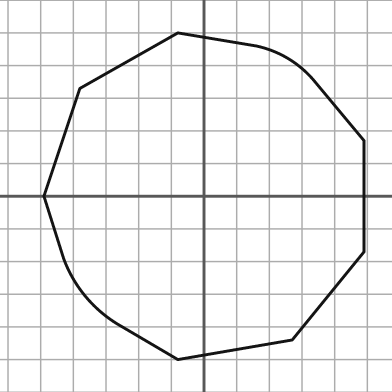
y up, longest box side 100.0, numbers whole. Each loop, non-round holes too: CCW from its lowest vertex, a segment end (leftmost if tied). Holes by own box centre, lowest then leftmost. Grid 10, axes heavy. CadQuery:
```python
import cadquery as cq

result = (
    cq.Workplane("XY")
    .moveTo(-8.0, -50.0)
    .lineTo(27.0, -44.0)
    .lineTo(49.0, -17.0)
    .lineTo(49.0, 17.0)
    .lineTo(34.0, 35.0)
    .threePointArc((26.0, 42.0), (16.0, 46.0))
    .lineTo(-8.0, 50.0)
    .lineTo(-38.0, 33.0)
    .lineTo(-49.0, 0.0)
    .lineTo(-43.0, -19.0)
    .threePointArc((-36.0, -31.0), (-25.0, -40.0))
    .close()
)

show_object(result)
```